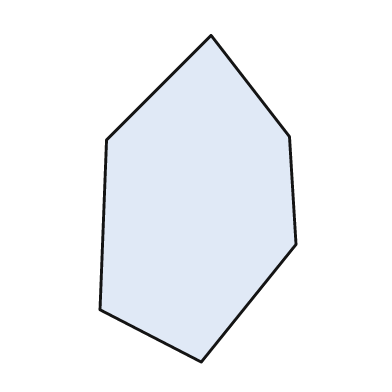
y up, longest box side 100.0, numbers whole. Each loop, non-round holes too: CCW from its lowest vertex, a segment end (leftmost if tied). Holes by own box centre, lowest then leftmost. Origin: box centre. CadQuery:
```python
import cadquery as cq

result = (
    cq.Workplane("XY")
    .moveTo(1.0, -50.0)
    .lineTo(30.0, -14.0)
    .lineTo(28.0, 19.0)
    .lineTo(4.0, 50.0)
    .lineTo(-28.0, 18.0)
    .lineTo(-30.0, -34.0)
    .close()
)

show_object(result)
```